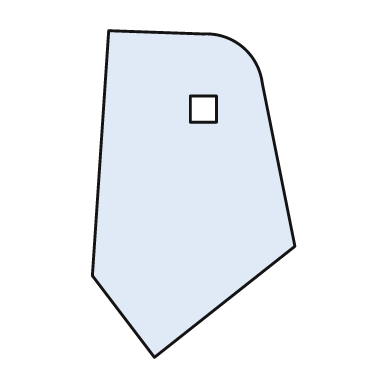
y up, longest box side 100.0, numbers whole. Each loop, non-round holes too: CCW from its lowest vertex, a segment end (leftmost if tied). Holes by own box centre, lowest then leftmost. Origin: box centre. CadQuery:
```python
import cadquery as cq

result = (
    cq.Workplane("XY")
    .moveTo(-12.0, -50.0)
    .lineTo(31.0, -16.0)
    .lineTo(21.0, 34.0)
    .threePointArc((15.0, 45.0), (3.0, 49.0))
    .lineTo(-26.0, 50.0)
    .lineTo(-31.0, -25.0)
    .close()
    .moveTo(-1.0, 22.0)
    .lineTo(7.0, 22.0)
    .lineTo(7.0, 30.0)
    .lineTo(-1.0, 30.0)
    .close()
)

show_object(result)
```